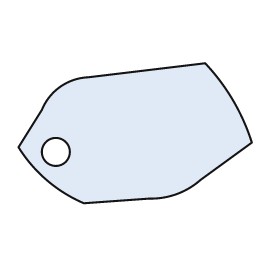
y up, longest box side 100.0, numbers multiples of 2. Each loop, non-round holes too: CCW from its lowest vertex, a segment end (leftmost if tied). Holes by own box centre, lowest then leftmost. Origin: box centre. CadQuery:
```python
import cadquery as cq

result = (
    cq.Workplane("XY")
    .moveTo(-22.0, -30.0)
    .lineTo(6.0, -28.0)
    .threePointArc((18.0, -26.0), (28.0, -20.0))
    .lineTo(50.0, -4.0)
    .threePointArc((42.0, 14.0), (30.0, 30.0))
    .lineTo(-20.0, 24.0)
    .threePointArc((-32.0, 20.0), (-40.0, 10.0))
    .lineTo(-50.0, -6.0)
    .threePointArc((-38.0, -20.0), (-22.0, -30.0))
    .close()
    .moveTo(-34.0, -8.0)
    .circle(6.0)
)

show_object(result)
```